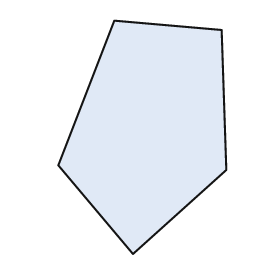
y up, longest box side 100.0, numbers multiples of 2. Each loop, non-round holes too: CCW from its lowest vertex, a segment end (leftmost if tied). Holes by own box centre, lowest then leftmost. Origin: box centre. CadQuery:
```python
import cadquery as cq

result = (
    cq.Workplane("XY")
    .moveTo(-4.0, -50.0)
    .lineTo(36.0, -14.0)
    .lineTo(34.0, 46.0)
    .lineTo(-12.0, 50.0)
    .lineTo(-36.0, -12.0)
    .close()
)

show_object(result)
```